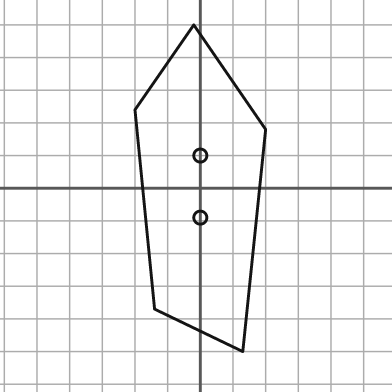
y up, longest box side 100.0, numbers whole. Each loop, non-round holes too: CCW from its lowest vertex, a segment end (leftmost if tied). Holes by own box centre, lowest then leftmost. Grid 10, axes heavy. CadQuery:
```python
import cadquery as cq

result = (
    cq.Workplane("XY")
    .moveTo(13.0, -50.0)
    .lineTo(20.0, 18.0)
    .lineTo(-2.0, 50.0)
    .lineTo(-20.0, 24.0)
    .lineTo(-14.0, -37.0)
    .close()
    .moveTo(0.0, -9.0)
    .circle(2.0)
    .moveTo(0.0, 10.0)
    .circle(2.0)
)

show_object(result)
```